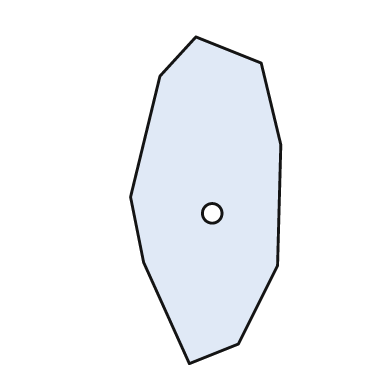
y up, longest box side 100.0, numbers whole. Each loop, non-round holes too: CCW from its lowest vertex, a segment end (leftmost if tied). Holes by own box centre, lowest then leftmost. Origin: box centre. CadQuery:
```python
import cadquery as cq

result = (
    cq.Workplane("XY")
    .moveTo(-5.0, -50.0)
    .lineTo(10.0, -44.0)
    .lineTo(22.0, -20.0)
    .lineTo(23.0, 17.0)
    .lineTo(17.0, 42.0)
    .lineTo(-3.0, 50.0)
    .lineTo(-14.0, 38.0)
    .lineTo(-23.0, 1.0)
    .lineTo(-19.0, -19.0)
    .close()
    .moveTo(2.0, -4.0)
    .circle(3.0)
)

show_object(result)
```